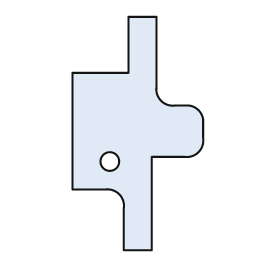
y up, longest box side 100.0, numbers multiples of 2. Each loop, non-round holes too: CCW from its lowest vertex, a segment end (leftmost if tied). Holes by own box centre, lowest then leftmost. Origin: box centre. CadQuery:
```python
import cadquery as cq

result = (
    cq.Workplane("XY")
    .moveTo(-6.0, -50.0)
    .lineTo(6.0, -50.0)
    .lineTo(6.0, -10.0)
    .lineTo(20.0, -10.0)
    .threePointArc((26.0, -8.0), (28.0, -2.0))
    .lineTo(28.0, 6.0)
    .threePointArc((26.0, 10.0), (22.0, 12.0))
    .lineTo(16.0, 12.0)
    .threePointArc((10.0, 14.0), (8.0, 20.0))
    .lineTo(8.0, 50.0)
    .lineTo(-4.0, 50.0)
    .lineTo(-4.0, 26.0)
    .lineTo(-28.0, 26.0)
    .lineTo(-28.0, -24.0)
    .lineTo(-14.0, -24.0)
    .threePointArc((-8.0, -26.0), (-6.0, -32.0))
    .close()
    .moveTo(-12.0, -12.0)
    .circle(4.0)
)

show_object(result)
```